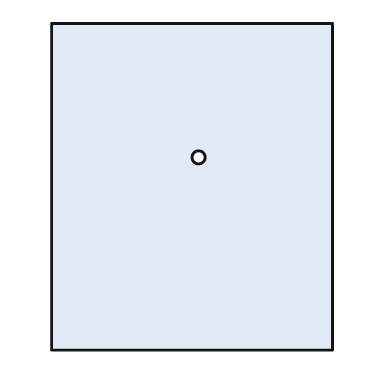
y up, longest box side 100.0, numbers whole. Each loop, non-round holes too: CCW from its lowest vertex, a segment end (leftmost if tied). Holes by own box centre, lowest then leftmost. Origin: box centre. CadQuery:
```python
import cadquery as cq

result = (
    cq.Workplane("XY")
    .moveTo(-43.0, -50.0)
    .lineTo(43.0, -50.0)
    .lineTo(43.0, 50.0)
    .lineTo(-43.0, 50.0)
    .close()
    .moveTo(2.0, 9.0)
    .circle(2.0)
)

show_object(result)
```